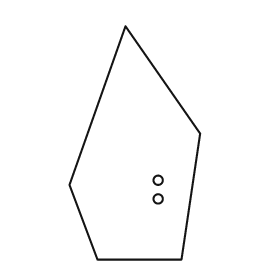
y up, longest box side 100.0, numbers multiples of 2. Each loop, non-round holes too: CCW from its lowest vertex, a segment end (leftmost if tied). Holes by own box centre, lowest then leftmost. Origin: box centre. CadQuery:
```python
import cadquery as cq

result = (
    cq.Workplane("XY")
    .moveTo(-16.0, -50.0)
    .lineTo(20.0, -50.0)
    .lineTo(28.0, 4.0)
    .lineTo(-4.0, 50.0)
    .lineTo(-28.0, -18.0)
    .close()
    .moveTo(10.0, -24.0)
    .circle(2.0)
    .moveTo(10.0, -16.0)
    .circle(2.0)
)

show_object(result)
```